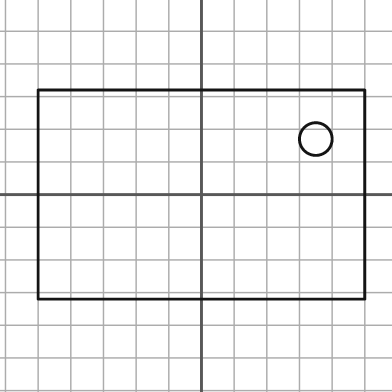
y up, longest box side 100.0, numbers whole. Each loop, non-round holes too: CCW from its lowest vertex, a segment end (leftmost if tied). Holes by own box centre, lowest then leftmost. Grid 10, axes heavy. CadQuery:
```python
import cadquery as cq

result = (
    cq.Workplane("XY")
    .moveTo(-50.0, -32.0)
    .lineTo(50.0, -32.0)
    .lineTo(50.0, 32.0)
    .lineTo(-50.0, 32.0)
    .close()
    .moveTo(35.0, 17.0)
    .circle(5.0)
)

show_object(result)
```